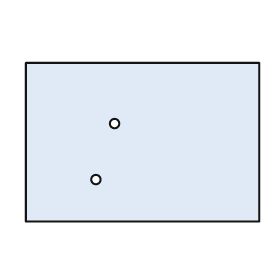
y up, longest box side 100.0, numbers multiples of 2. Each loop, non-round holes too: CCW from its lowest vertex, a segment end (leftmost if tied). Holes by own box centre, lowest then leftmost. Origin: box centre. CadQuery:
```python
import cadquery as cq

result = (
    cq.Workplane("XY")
    .moveTo(-50.0, -34.0)
    .lineTo(50.0, -34.0)
    .lineTo(50.0, 34.0)
    .lineTo(-50.0, 34.0)
    .close()
    .moveTo(-20.0, -16.0)
    .circle(2.0)
    .moveTo(-12.0, 8.0)
    .circle(2.0)
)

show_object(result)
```